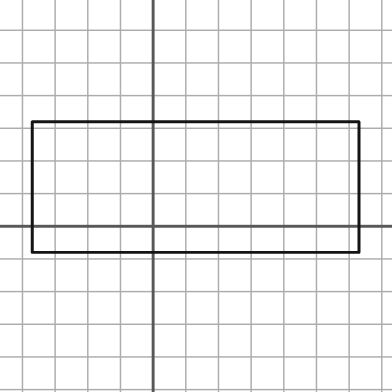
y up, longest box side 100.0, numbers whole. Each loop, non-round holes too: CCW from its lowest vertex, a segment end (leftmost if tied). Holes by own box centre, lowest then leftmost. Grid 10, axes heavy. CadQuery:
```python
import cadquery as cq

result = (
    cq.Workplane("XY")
    .moveTo(-37.0, -8.0)
    .lineTo(63.0, -8.0)
    .lineTo(63.0, 32.0)
    .lineTo(-37.0, 32.0)
    .close()
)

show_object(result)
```